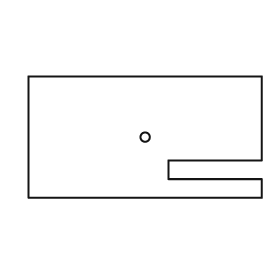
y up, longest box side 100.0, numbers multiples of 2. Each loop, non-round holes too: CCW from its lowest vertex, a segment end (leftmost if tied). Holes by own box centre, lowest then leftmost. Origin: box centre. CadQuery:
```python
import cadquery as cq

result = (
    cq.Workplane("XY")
    .moveTo(-50.0, -26.0)
    .lineTo(50.0, -26.0)
    .lineTo(50.0, -18.0)
    .lineTo(10.0, -18.0)
    .lineTo(10.0, -10.0)
    .lineTo(50.0, -10.0)
    .lineTo(50.0, 26.0)
    .lineTo(-50.0, 26.0)
    .close()
    .moveTo(0.0, 0.0)
    .circle(2.0)
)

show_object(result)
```